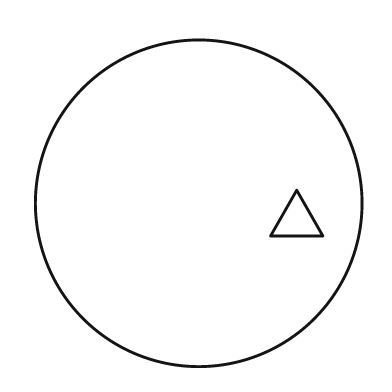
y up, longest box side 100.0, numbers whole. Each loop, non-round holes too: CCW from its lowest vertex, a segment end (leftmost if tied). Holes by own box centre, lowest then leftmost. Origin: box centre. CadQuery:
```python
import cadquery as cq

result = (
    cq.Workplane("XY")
    .moveTo(0.0, 0.0)
    .circle(50.0)
    .moveTo(22.0, -10.0)
    .lineTo(38.0, -10.0)
    .lineTo(30.0, 4.0)
    .close()
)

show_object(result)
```